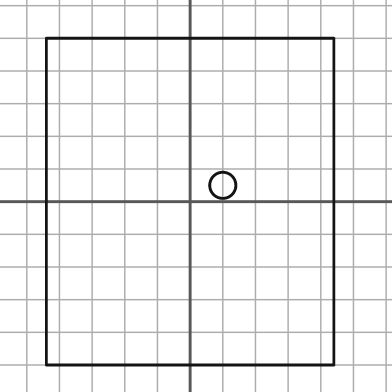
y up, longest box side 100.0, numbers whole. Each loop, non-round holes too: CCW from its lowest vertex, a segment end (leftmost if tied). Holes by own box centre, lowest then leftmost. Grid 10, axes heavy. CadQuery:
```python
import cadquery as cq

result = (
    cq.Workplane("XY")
    .moveTo(-44.0, -50.0)
    .lineTo(44.0, -50.0)
    .lineTo(44.0, 50.0)
    .lineTo(-44.0, 50.0)
    .close()
    .moveTo(10.0, 5.0)
    .circle(4.0)
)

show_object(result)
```